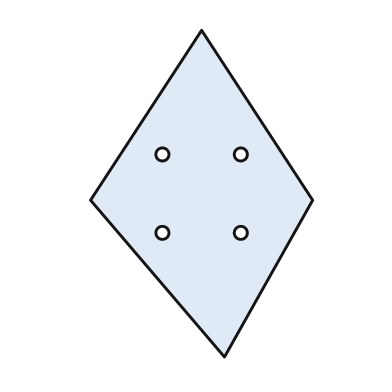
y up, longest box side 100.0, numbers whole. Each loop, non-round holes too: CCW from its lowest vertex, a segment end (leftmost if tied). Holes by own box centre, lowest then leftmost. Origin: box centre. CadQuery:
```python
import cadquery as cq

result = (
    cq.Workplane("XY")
    .moveTo(7.0, -50.0)
    .lineTo(34.0, -2.0)
    .lineTo(0.0, 50.0)
    .lineTo(-34.0, -2.0)
    .close()
    .moveTo(-12.0, -12.0)
    .circle(2.0)
    .moveTo(12.0, -12.0)
    .circle(2.0)
    .moveTo(-12.0, 12.0)
    .circle(2.0)
    .moveTo(12.0, 12.0)
    .circle(2.0)
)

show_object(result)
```